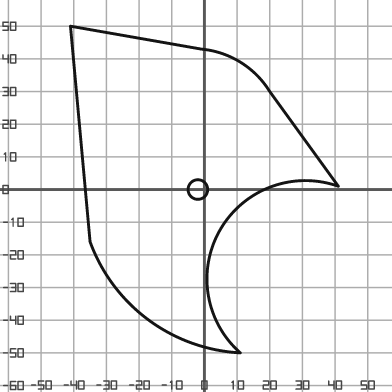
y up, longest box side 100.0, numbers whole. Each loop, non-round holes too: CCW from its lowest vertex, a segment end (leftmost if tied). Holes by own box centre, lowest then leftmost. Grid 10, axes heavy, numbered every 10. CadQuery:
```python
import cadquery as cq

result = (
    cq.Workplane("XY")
    .moveTo(11.0, -50.0)
    .threePointArc((5.0, -12.0), (41.0, 1.0))
    .lineTo(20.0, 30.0)
    .threePointArc((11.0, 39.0), (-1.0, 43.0))
    .lineTo(-41.0, 50.0)
    .lineTo(-35.0, -16.0)
    .threePointArc((-17.0, -40.0), (11.0, -50.0))
    .close()
    .moveTo(-2.0, 0.0)
    .circle(3.0)
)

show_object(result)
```